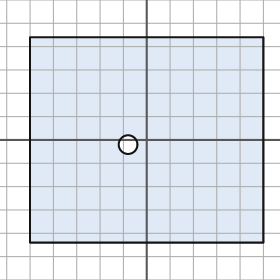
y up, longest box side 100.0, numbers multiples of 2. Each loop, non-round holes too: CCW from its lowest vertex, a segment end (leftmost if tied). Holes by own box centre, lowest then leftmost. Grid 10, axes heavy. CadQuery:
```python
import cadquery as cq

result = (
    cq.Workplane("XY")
    .moveTo(-50.0, -44.0)
    .lineTo(50.0, -44.0)
    .lineTo(50.0, 44.0)
    .lineTo(-50.0, 44.0)
    .close()
    .moveTo(-8.0, -2.0)
    .circle(4.0)
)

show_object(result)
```